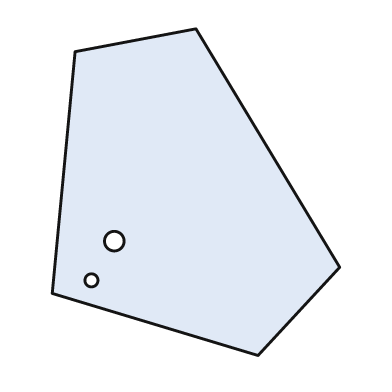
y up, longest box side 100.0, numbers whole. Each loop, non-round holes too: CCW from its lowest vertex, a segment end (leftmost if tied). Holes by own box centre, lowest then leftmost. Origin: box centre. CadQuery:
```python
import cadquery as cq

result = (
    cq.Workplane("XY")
    .moveTo(19.0, -50.0)
    .lineTo(44.0, -23.0)
    .lineTo(0.0, 50.0)
    .lineTo(-37.0, 43.0)
    .lineTo(-44.0, -31.0)
    .close()
    .moveTo(-32.0, -27.0)
    .circle(2.0)
    .moveTo(-25.0, -15.0)
    .circle(3.0)
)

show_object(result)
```